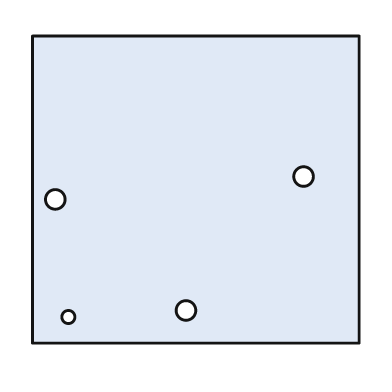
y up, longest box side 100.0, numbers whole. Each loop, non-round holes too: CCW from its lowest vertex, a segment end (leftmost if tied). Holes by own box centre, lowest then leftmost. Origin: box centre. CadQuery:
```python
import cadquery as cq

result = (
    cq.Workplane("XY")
    .moveTo(-50.0, -47.0)
    .lineTo(50.0, -47.0)
    .lineTo(50.0, 47.0)
    .lineTo(-50.0, 47.0)
    .close()
    .moveTo(-39.0, -39.0)
    .circle(2.0)
    .moveTo(-3.0, -37.0)
    .circle(3.0)
    .moveTo(-43.0, -3.0)
    .circle(3.0)
    .moveTo(33.0, 4.0)
    .circle(3.0)
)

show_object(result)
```